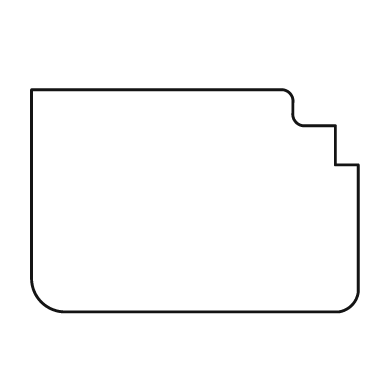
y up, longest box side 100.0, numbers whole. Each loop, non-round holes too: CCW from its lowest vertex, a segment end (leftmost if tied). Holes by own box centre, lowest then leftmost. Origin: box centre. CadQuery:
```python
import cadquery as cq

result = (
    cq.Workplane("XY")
    .moveTo(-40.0, -34.0)
    .lineTo(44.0, -34.0)
    .threePointArc((48.0, -32.0), (50.0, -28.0))
    .lineTo(50.0, 11.0)
    .lineTo(43.0, 11.0)
    .lineTo(43.0, 23.0)
    .lineTo(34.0, 23.0)
    .threePointArc((31.0, 24.0), (30.0, 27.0))
    .lineTo(30.0, 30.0)
    .threePointArc((29.0, 33.0), (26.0, 34.0))
    .lineTo(-50.0, 34.0)
    .lineTo(-50.0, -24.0)
    .threePointArc((-47.0, -31.0), (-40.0, -34.0))
    .close()
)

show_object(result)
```